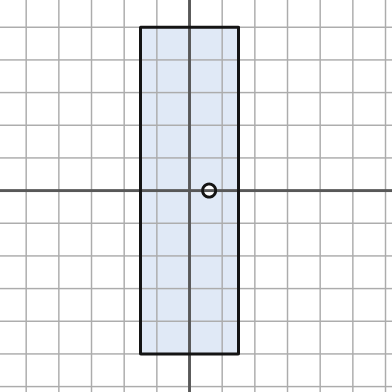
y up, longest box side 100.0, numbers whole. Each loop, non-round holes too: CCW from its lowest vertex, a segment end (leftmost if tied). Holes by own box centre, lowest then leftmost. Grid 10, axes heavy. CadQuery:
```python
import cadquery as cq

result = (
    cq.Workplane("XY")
    .moveTo(-15.0, -50.0)
    .lineTo(15.0, -50.0)
    .lineTo(15.0, 50.0)
    .lineTo(-15.0, 50.0)
    .close()
    .moveTo(6.0, 0.0)
    .circle(2.0)
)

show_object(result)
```